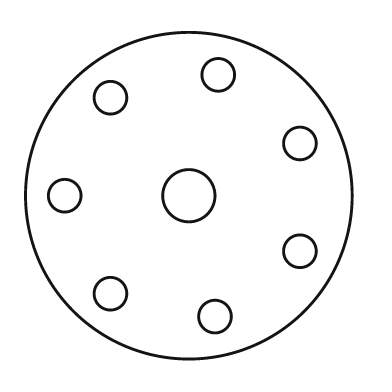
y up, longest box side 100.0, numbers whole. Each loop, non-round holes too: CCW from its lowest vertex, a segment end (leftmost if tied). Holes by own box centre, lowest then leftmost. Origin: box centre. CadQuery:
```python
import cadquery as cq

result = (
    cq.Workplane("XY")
    .moveTo(0.0, 0.0)
    .circle(50.0)
    .moveTo(8.0, -37.0)
    .circle(5.0)
    .moveTo(-24.0, -30.0)
    .circle(5.0)
    .moveTo(34.0, -17.0)
    .circle(5.0)
    .moveTo(-38.0, 0.0)
    .circle(5.0)
    .moveTo(0.0, 0.0)
    .circle(8.0)
    .moveTo(34.0, 16.0)
    .circle(5.0)
    .moveTo(-24.0, 30.0)
    .circle(5.0)
    .moveTo(9.0, 37.0)
    .circle(5.0)
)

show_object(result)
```